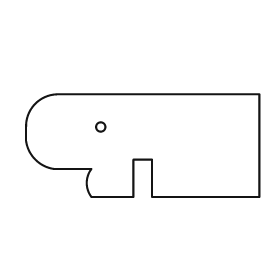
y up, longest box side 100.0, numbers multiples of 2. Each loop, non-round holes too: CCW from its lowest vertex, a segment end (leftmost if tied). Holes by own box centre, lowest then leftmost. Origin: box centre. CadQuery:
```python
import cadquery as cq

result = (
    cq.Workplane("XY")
    .moveTo(-22.0, -22.0)
    .lineTo(-4.0, -22.0)
    .lineTo(-4.0, -6.0)
    .lineTo(4.0, -6.0)
    .lineTo(4.0, -22.0)
    .lineTo(50.0, -22.0)
    .lineTo(50.0, 22.0)
    .lineTo(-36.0, 22.0)
    .threePointArc((-46.0, 18.0), (-50.0, 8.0))
    .lineTo(-50.0, 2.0)
    .threePointArc((-46.0, -6.0), (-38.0, -10.0))
    .lineTo(-22.0, -10.0)
    .threePointArc((-24.0, -16.0), (-22.0, -22.0))
    .close()
    .moveTo(-18.0, 8.0)
    .circle(2.0)
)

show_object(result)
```